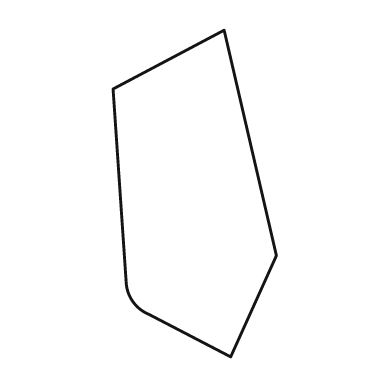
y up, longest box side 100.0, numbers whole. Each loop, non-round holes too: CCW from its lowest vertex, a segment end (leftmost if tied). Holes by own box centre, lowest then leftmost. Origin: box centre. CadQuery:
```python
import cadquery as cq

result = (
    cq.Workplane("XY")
    .moveTo(11.0, -50.0)
    .lineTo(25.0, -19.0)
    .lineTo(9.0, 50.0)
    .lineTo(-25.0, 32.0)
    .lineTo(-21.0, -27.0)
    .threePointArc((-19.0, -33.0), (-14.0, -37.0))
    .close()
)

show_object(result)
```